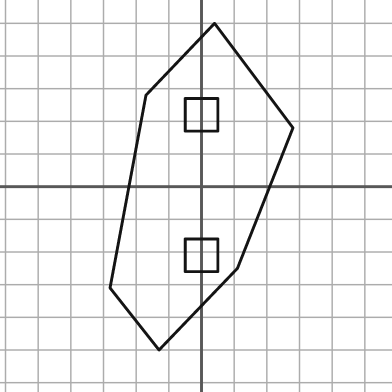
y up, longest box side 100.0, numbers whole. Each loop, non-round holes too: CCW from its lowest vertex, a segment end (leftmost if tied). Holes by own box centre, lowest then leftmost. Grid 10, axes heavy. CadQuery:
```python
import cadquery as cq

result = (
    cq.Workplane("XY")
    .moveTo(-13.0, -50.0)
    .lineTo(11.0, -25.0)
    .lineTo(28.0, 18.0)
    .lineTo(4.0, 50.0)
    .lineTo(-17.0, 28.0)
    .lineTo(-28.0, -31.0)
    .close()
    .moveTo(-5.0, -26.0)
    .lineTo(5.0, -26.0)
    .lineTo(5.0, -16.0)
    .lineTo(-5.0, -16.0)
    .close()
    .moveTo(-5.0, 17.0)
    .lineTo(5.0, 17.0)
    .lineTo(5.0, 27.0)
    .lineTo(-5.0, 27.0)
    .close()
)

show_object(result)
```